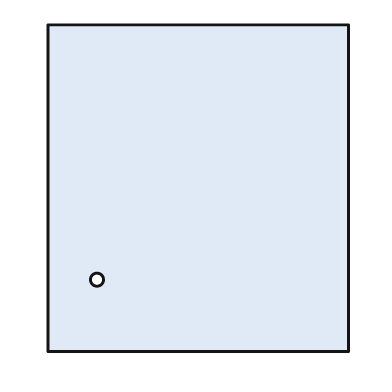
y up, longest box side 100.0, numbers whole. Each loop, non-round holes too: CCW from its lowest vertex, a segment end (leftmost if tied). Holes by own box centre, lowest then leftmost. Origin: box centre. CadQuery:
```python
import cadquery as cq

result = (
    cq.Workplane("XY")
    .moveTo(-46.0, -50.0)
    .lineTo(46.0, -50.0)
    .lineTo(46.0, 50.0)
    .lineTo(-46.0, 50.0)
    .close()
    .moveTo(-31.0, -28.0)
    .circle(2.0)
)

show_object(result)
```